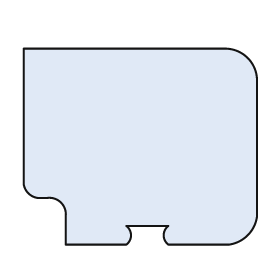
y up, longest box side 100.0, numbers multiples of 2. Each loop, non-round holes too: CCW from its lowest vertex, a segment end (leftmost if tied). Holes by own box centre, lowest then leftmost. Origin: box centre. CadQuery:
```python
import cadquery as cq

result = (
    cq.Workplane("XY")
    .moveTo(-32.0, -42.0)
    .lineTo(-6.0, -42.0)
    .threePointArc((-4.0, -38.0), (-6.0, -34.0))
    .lineTo(12.0, -34.0)
    .threePointArc((10.0, -38.0), (12.0, -42.0))
    .lineTo(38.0, -42.0)
    .threePointArc((46.0, -38.0), (50.0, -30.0))
    .lineTo(50.0, 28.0)
    .threePointArc((46.0, 38.0), (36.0, 42.0))
    .lineTo(-50.0, 42.0)
    .lineTo(-50.0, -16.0)
    .threePointArc((-48.0, -20.0), (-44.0, -22.0))
    .lineTo(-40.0, -22.0)
    .threePointArc((-34.0, -24.0), (-32.0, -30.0))
    .close()
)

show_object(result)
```